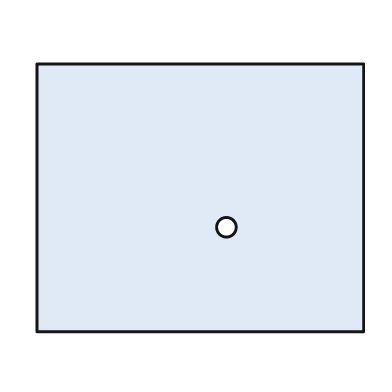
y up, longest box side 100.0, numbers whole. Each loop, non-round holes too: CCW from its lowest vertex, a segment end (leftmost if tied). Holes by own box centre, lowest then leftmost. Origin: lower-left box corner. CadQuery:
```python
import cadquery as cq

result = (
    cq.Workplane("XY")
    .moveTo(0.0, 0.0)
    .lineTo(100.0, 0.0)
    .lineTo(100.0, 82.0)
    .lineTo(0.0, 82.0)
    .close()
    .moveTo(58.0, 32.0)
    .circle(3.0)
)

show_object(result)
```